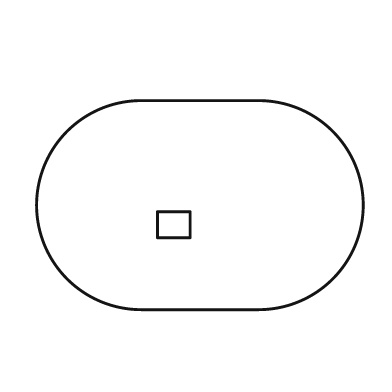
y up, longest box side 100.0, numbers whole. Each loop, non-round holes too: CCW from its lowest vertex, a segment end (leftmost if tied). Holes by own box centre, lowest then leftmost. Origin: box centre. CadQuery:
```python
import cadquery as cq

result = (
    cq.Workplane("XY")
    .moveTo(-18.0, -32.0)
    .lineTo(18.0, -32.0)
    .threePointArc((50.0, 0.0), (18.0, 32.0))
    .lineTo(-18.0, 32.0)
    .threePointArc((-50.0, 0.0), (-18.0, -32.0))
    .close()
    .moveTo(-13.0, -10.0)
    .lineTo(-3.0, -10.0)
    .lineTo(-3.0, -2.0)
    .lineTo(-13.0, -2.0)
    .close()
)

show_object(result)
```